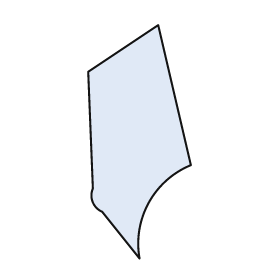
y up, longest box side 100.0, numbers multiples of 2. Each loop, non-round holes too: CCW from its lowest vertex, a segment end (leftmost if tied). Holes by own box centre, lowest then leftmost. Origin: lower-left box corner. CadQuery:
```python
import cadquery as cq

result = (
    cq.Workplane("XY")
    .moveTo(22.0, 0.0)
    .threePointArc((26.0, 24.0), (44.0, 40.0))
    .lineTo(30.0, 100.0)
    .lineTo(0.0, 80.0)
    .lineTo(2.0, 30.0)
    .threePointArc((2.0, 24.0), (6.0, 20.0))
    .close()
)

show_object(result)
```